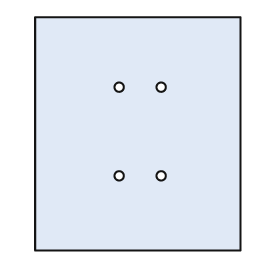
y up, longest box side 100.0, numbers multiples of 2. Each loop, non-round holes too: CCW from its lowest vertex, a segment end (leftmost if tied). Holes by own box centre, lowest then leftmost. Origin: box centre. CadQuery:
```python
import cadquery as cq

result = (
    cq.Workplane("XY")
    .moveTo(-44.0, -50.0)
    .lineTo(44.0, -50.0)
    .lineTo(44.0, 50.0)
    .lineTo(-44.0, 50.0)
    .close()
    .moveTo(-8.0, -18.0)
    .circle(2.0)
    .moveTo(10.0, -18.0)
    .circle(2.0)
    .moveTo(-8.0, 20.0)
    .circle(2.0)
    .moveTo(10.0, 20.0)
    .circle(2.0)
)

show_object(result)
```